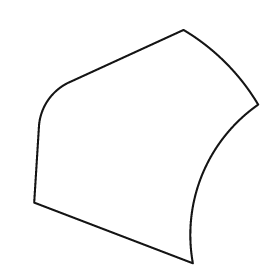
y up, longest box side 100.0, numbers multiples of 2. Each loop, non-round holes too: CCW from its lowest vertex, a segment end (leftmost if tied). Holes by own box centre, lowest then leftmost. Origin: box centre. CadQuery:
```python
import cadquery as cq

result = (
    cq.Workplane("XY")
    .moveTo(20.0, -50.0)
    .threePointArc((24.0, -12.0), (48.0, 18.0))
    .threePointArc((34.0, 36.0), (16.0, 50.0))
    .lineTo(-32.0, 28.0)
    .threePointArc((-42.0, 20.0), (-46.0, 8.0))
    .lineTo(-48.0, -24.0)
    .close()
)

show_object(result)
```